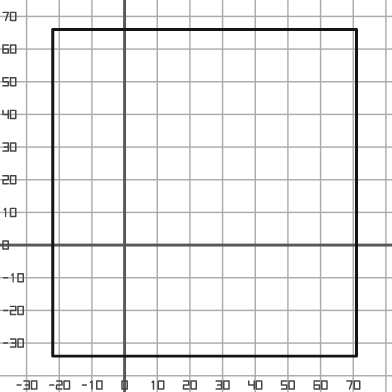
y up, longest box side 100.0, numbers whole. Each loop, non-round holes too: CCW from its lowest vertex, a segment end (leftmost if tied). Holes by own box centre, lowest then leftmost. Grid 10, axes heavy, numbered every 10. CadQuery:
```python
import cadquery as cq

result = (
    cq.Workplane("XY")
    .moveTo(-22.0, -34.0)
    .lineTo(71.0, -34.0)
    .lineTo(71.0, 66.0)
    .lineTo(-22.0, 66.0)
    .close()
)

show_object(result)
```